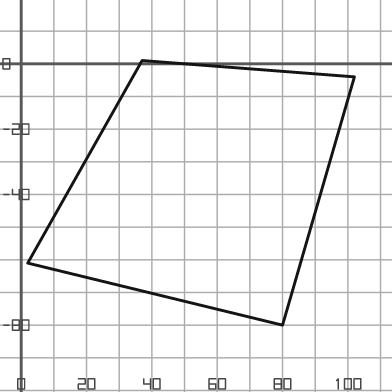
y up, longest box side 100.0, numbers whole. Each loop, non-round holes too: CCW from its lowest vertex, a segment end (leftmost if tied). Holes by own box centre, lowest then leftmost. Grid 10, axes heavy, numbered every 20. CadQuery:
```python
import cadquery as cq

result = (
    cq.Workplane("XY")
    .moveTo(80.0, -80.0)
    .lineTo(102.0, -4.0)
    .lineTo(37.0, 1.0)
    .lineTo(2.0, -61.0)
    .close()
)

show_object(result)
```